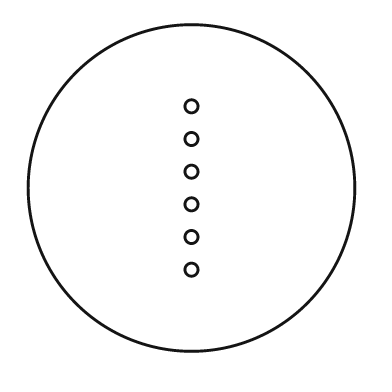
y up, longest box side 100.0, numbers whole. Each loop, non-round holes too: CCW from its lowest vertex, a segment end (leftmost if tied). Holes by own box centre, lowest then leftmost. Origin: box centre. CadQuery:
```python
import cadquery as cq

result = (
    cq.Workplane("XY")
    .moveTo(0.0, 0.0)
    .circle(50.0)
    .moveTo(0.0, -25.0)
    .circle(2.0)
    .moveTo(0.0, -15.0)
    .circle(2.0)
    .moveTo(0.0, -5.0)
    .circle(2.0)
    .moveTo(0.0, 5.0)
    .circle(2.0)
    .moveTo(0.0, 15.0)
    .circle(2.0)
    .moveTo(0.0, 25.0)
    .circle(2.0)
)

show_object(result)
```